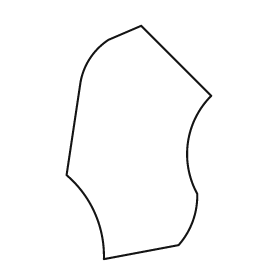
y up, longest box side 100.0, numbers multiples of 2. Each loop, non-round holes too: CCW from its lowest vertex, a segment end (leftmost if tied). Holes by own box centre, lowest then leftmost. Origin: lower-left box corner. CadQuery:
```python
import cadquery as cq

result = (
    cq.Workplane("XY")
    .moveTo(16.0, 0.0)
    .lineTo(48.0, 6.0)
    .threePointArc((54.0, 16.0), (56.0, 28.0))
    .threePointArc((52.0, 50.0), (62.0, 70.0))
    .lineTo(32.0, 100.0)
    .lineTo(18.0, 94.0)
    .threePointArc((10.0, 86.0), (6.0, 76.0))
    .lineTo(0.0, 36.0)
    .threePointArc((12.0, 20.0), (16.0, 0.0))
    .close()
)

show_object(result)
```